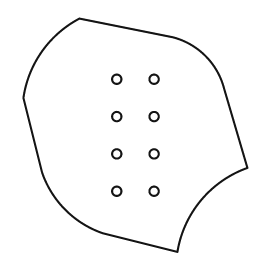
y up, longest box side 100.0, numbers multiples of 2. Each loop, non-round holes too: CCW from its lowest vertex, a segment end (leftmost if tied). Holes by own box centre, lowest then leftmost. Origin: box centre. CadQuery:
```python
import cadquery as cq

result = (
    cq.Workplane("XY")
    .moveTo(18.0, -50.0)
    .threePointArc((28.0, -28.0), (48.0, -14.0))
    .lineTo(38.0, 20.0)
    .threePointArc((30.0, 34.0), (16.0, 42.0))
    .lineTo(-24.0, 50.0)
    .threePointArc((-40.0, 36.0), (-48.0, 16.0))
    .lineTo(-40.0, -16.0)
    .threePointArc((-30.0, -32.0), (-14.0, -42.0))
    .close()
    .moveTo(-8.0, -24.0)
    .circle(2.0)
    .moveTo(8.0, -24.0)
    .circle(2.0)
    .moveTo(-8.0, -8.0)
    .circle(2.0)
    .moveTo(8.0, -8.0)
    .circle(2.0)
    .moveTo(-8.0, 8.0)
    .circle(2.0)
    .moveTo(8.0, 8.0)
    .circle(2.0)
    .moveTo(-8.0, 24.0)
    .circle(2.0)
    .moveTo(8.0, 24.0)
    .circle(2.0)
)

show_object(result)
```